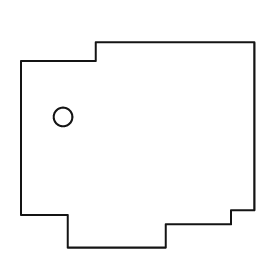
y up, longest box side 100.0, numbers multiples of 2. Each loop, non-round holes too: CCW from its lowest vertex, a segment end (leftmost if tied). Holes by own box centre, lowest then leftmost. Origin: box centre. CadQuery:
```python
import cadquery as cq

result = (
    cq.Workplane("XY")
    .moveTo(-30.0, -44.0)
    .lineTo(12.0, -44.0)
    .lineTo(12.0, -34.0)
    .lineTo(40.0, -34.0)
    .lineTo(40.0, -28.0)
    .lineTo(50.0, -28.0)
    .lineTo(50.0, 44.0)
    .lineTo(-18.0, 44.0)
    .lineTo(-18.0, 36.0)
    .lineTo(-50.0, 36.0)
    .lineTo(-50.0, -30.0)
    .lineTo(-30.0, -30.0)
    .close()
    .moveTo(-32.0, 12.0)
    .circle(4.0)
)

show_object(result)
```